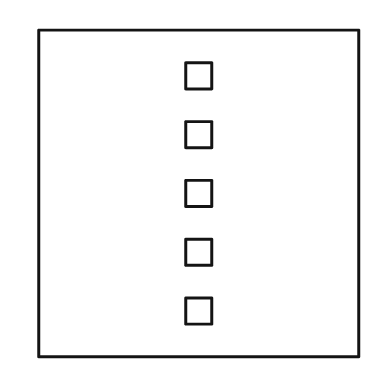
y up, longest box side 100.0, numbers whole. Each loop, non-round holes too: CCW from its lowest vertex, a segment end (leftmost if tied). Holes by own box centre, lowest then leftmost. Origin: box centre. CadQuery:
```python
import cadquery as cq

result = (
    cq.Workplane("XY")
    .moveTo(-49.0, -50.0)
    .lineTo(49.0, -50.0)
    .lineTo(49.0, 50.0)
    .lineTo(-49.0, 50.0)
    .close()
    .moveTo(-4.0, -40.0)
    .lineTo(4.0, -40.0)
    .lineTo(4.0, -32.0)
    .lineTo(-4.0, -32.0)
    .close()
    .moveTo(-4.0, -22.0)
    .lineTo(4.0, -22.0)
    .lineTo(4.0, -14.0)
    .lineTo(-4.0, -14.0)
    .close()
    .moveTo(-4.0, -4.0)
    .lineTo(4.0, -4.0)
    .lineTo(4.0, 4.0)
    .lineTo(-4.0, 4.0)
    .close()
    .moveTo(-4.0, 14.0)
    .lineTo(4.0, 14.0)
    .lineTo(4.0, 22.0)
    .lineTo(-4.0, 22.0)
    .close()
    .moveTo(-4.0, 32.0)
    .lineTo(4.0, 32.0)
    .lineTo(4.0, 40.0)
    .lineTo(-4.0, 40.0)
    .close()
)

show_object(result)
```